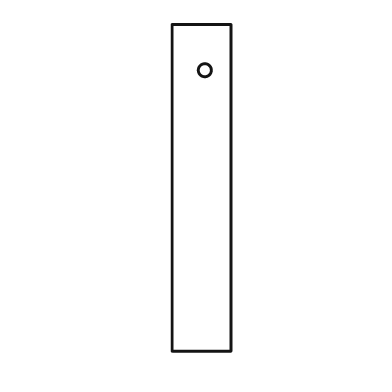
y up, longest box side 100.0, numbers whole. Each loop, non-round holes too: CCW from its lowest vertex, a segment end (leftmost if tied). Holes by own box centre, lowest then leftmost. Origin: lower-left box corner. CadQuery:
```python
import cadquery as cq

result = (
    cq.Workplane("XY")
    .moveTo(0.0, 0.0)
    .lineTo(18.0, 0.0)
    .lineTo(18.0, 100.0)
    .lineTo(0.0, 100.0)
    .close()
    .moveTo(10.0, 86.0)
    .circle(2.0)
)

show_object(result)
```